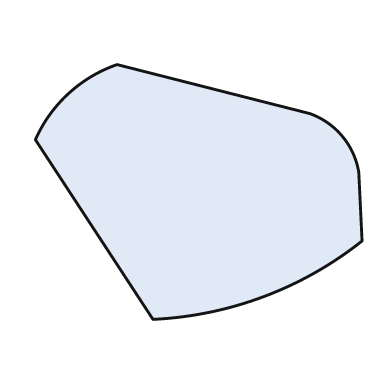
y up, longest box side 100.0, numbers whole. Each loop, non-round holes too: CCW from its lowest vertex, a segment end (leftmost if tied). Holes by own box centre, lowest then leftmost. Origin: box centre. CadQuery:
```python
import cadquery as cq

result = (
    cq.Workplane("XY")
    .moveTo(-14.0, -39.0)
    .threePointArc((20.0, -32.0), (50.0, -15.0))
    .lineTo(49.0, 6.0)
    .threePointArc((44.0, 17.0), (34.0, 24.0))
    .lineTo(-25.0, 39.0)
    .threePointArc((-40.0, 30.0), (-50.0, 16.0))
    .close()
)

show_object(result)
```